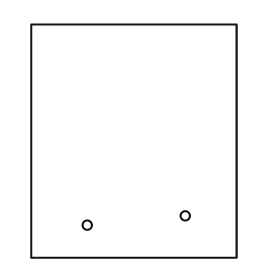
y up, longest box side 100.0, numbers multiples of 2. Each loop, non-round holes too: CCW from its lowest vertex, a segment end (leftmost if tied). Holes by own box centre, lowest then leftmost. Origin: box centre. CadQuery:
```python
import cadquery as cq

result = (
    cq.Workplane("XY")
    .moveTo(-44.0, -50.0)
    .lineTo(44.0, -50.0)
    .lineTo(44.0, 50.0)
    .lineTo(-44.0, 50.0)
    .close()
    .moveTo(-20.0, -36.0)
    .circle(2.0)
    .moveTo(22.0, -32.0)
    .circle(2.0)
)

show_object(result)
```